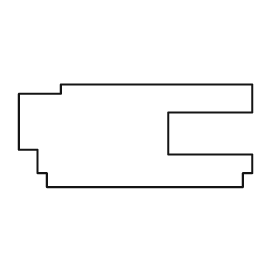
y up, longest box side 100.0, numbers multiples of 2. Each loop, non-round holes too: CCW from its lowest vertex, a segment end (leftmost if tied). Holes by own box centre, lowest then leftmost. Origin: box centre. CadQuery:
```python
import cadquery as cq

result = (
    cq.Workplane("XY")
    .moveTo(-38.0, -22.0)
    .lineTo(46.0, -22.0)
    .lineTo(46.0, -16.0)
    .lineTo(50.0, -16.0)
    .lineTo(50.0, -8.0)
    .lineTo(14.0, -8.0)
    .lineTo(14.0, 10.0)
    .lineTo(50.0, 10.0)
    .lineTo(50.0, 22.0)
    .lineTo(-32.0, 22.0)
    .lineTo(-32.0, 18.0)
    .lineTo(-50.0, 18.0)
    .lineTo(-50.0, -6.0)
    .lineTo(-42.0, -6.0)
    .lineTo(-42.0, -16.0)
    .lineTo(-38.0, -16.0)
    .close()
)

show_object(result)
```